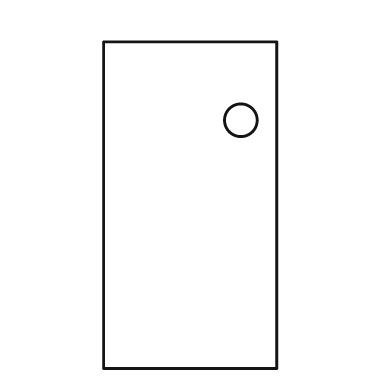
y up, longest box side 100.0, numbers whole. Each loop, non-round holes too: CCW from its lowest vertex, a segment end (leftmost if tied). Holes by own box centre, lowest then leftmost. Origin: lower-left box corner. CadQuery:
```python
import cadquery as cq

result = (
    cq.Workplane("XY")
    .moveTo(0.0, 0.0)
    .lineTo(53.0, 0.0)
    .lineTo(53.0, 100.0)
    .lineTo(0.0, 100.0)
    .close()
    .moveTo(42.0, 76.0)
    .circle(5.0)
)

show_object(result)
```